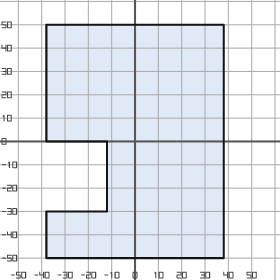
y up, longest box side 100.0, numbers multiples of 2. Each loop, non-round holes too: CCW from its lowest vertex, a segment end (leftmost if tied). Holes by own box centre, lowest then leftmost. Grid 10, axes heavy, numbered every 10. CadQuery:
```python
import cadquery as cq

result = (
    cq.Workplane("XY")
    .moveTo(-38.0, -50.0)
    .lineTo(38.0, -50.0)
    .lineTo(38.0, 50.0)
    .lineTo(-38.0, 50.0)
    .lineTo(-38.0, 0.0)
    .lineTo(-12.0, 0.0)
    .lineTo(-12.0, -30.0)
    .lineTo(-38.0, -30.0)
    .close()
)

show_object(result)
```